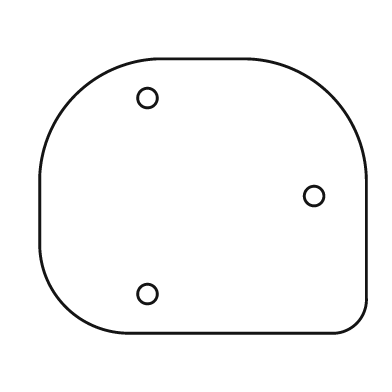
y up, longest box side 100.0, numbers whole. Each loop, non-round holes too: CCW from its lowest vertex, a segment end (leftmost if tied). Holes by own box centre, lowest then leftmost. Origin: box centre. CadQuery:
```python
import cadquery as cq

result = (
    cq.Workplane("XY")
    .moveTo(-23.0, -42.0)
    .lineTo(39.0, -42.0)
    .threePointArc((47.0, -39.0), (50.0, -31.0))
    .lineTo(50.0, 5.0)
    .threePointArc((39.0, 31.0), (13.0, 42.0))
    .lineTo(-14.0, 42.0)
    .threePointArc((-39.0, 31.0), (-50.0, 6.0))
    .lineTo(-50.0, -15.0)
    .threePointArc((-42.0, -34.0), (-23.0, -42.0))
    .close()
    .moveTo(-17.0, -30.0)
    .circle(3.0)
    .moveTo(34.0, 0.0)
    .circle(3.0)
    .moveTo(-17.0, 30.0)
    .circle(3.0)
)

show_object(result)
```